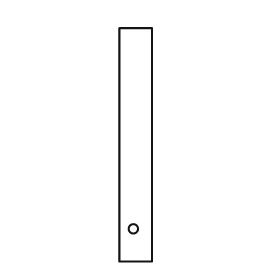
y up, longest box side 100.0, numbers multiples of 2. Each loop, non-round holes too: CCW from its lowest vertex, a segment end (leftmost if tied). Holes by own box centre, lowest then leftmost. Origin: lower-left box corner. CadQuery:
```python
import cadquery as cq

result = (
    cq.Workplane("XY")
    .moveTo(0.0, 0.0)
    .lineTo(14.0, 0.0)
    .lineTo(14.0, 100.0)
    .lineTo(0.0, 100.0)
    .close()
    .moveTo(6.0, 14.0)
    .circle(2.0)
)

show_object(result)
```